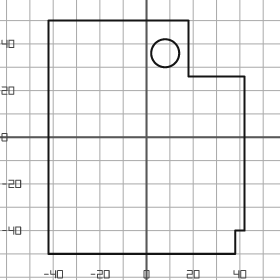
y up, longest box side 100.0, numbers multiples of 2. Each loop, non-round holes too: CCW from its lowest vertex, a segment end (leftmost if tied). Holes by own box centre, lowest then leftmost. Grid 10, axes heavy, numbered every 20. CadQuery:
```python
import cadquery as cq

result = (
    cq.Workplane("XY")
    .moveTo(-42.0, -50.0)
    .lineTo(38.0, -50.0)
    .lineTo(38.0, -40.0)
    .lineTo(42.0, -40.0)
    .lineTo(42.0, 26.0)
    .lineTo(18.0, 26.0)
    .lineTo(18.0, 50.0)
    .lineTo(-42.0, 50.0)
    .close()
    .moveTo(8.0, 36.0)
    .circle(6.0)
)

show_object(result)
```